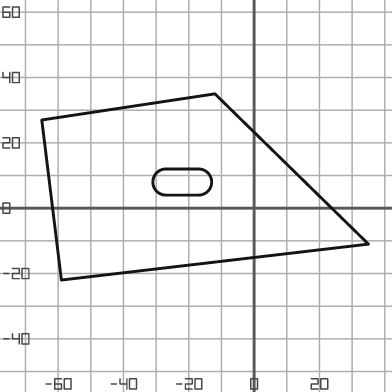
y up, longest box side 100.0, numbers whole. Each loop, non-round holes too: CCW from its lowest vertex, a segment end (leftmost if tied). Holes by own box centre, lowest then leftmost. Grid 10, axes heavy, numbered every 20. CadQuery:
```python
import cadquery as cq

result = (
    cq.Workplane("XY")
    .moveTo(-59.0, -22.0)
    .lineTo(35.0, -11.0)
    .lineTo(-12.0, 35.0)
    .lineTo(-65.0, 27.0)
    .close()
    .moveTo(-27.0, 4.0)
    .lineTo(-17.0, 4.0)
    .threePointArc((-13.0, 8.0), (-17.0, 12.0))
    .lineTo(-27.0, 12.0)
    .threePointArc((-31.0, 8.0), (-27.0, 4.0))
    .close()
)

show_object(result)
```